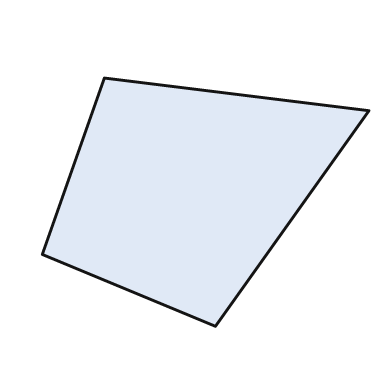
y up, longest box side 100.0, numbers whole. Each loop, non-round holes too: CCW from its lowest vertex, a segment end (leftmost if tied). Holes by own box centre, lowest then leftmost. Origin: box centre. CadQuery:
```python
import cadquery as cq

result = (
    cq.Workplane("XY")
    .moveTo(3.0, -38.0)
    .lineTo(50.0, 28.0)
    .lineTo(-31.0, 38.0)
    .lineTo(-50.0, -16.0)
    .close()
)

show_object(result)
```